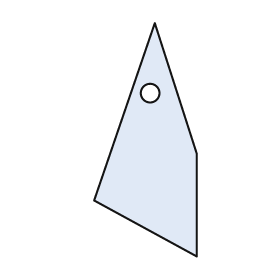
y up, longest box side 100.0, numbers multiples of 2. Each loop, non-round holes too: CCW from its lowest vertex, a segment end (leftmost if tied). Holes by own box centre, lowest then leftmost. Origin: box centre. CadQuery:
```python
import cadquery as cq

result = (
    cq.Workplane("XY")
    .moveTo(22.0, -50.0)
    .lineTo(22.0, -6.0)
    .lineTo(4.0, 50.0)
    .lineTo(-22.0, -26.0)
    .close()
    .moveTo(2.0, 20.0)
    .circle(4.0)
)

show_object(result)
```